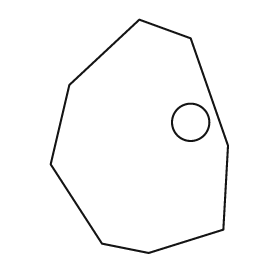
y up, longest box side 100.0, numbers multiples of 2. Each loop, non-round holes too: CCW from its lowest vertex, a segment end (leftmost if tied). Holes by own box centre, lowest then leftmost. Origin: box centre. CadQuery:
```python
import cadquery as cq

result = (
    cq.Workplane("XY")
    .moveTo(4.0, -50.0)
    .lineTo(36.0, -40.0)
    .lineTo(38.0, -4.0)
    .lineTo(22.0, 42.0)
    .lineTo(0.0, 50.0)
    .lineTo(-30.0, 22.0)
    .lineTo(-38.0, -12.0)
    .lineTo(-16.0, -46.0)
    .close()
    .moveTo(22.0, 6.0)
    .circle(8.0)
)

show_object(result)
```